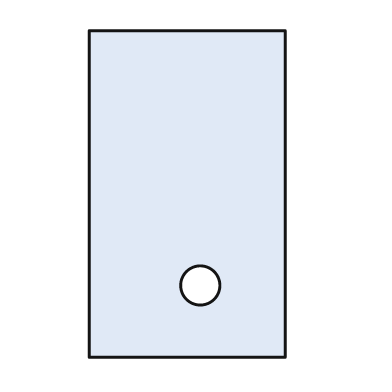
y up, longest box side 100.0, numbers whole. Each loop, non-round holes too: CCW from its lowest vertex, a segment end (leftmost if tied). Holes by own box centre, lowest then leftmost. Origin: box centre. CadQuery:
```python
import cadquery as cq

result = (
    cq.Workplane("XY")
    .moveTo(-30.0, -50.0)
    .lineTo(30.0, -50.0)
    .lineTo(30.0, 50.0)
    .lineTo(-30.0, 50.0)
    .close()
    .moveTo(4.0, -28.0)
    .circle(6.0)
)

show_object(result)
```